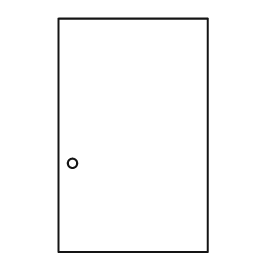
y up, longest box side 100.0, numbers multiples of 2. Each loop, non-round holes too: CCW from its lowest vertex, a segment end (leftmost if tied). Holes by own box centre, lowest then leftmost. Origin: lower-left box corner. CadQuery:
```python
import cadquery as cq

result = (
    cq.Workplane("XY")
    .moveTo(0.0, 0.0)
    .lineTo(64.0, 0.0)
    .lineTo(64.0, 100.0)
    .lineTo(0.0, 100.0)
    .close()
    .moveTo(6.0, 38.0)
    .circle(2.0)
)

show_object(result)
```